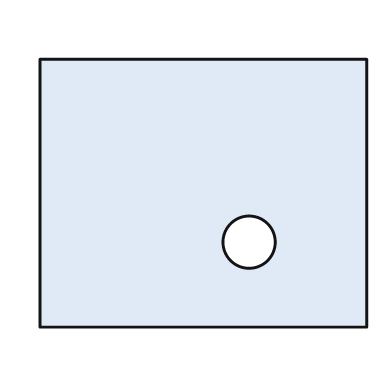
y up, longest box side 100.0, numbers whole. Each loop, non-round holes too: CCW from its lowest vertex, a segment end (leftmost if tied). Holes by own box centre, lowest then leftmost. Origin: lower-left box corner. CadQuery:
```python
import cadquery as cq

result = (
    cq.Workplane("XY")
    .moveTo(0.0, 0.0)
    .lineTo(100.0, 0.0)
    .lineTo(100.0, 82.0)
    .lineTo(0.0, 82.0)
    .close()
    .moveTo(64.0, 26.0)
    .circle(8.0)
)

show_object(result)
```